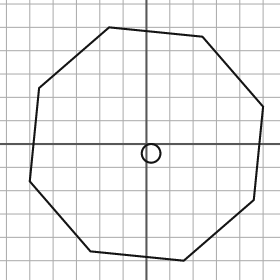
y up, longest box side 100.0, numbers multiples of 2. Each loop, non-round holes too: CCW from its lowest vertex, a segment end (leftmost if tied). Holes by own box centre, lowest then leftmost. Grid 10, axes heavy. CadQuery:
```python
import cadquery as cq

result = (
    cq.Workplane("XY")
    .moveTo(16.0, -50.0)
    .lineTo(46.0, -24.0)
    .lineTo(50.0, 16.0)
    .lineTo(24.0, 46.0)
    .lineTo(-16.0, 50.0)
    .lineTo(-46.0, 24.0)
    .lineTo(-50.0, -16.0)
    .lineTo(-24.0, -46.0)
    .close()
    .moveTo(2.0, -4.0)
    .circle(4.0)
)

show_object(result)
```